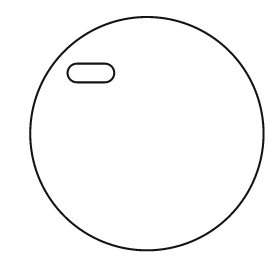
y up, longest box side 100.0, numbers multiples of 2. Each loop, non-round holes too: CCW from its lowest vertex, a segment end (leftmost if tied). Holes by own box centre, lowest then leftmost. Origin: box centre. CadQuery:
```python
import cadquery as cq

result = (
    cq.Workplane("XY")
    .moveTo(0.0, 0.0)
    .circle(50.0)
    .moveTo(-30.0, 22.0)
    .lineTo(-18.0, 22.0)
    .threePointArc((-14.0, 26.0), (-18.0, 30.0))
    .lineTo(-30.0, 30.0)
    .threePointArc((-34.0, 26.0), (-30.0, 22.0))
    .close()
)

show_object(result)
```